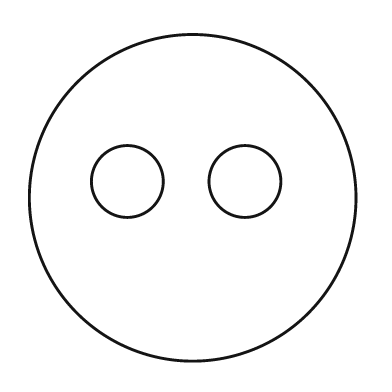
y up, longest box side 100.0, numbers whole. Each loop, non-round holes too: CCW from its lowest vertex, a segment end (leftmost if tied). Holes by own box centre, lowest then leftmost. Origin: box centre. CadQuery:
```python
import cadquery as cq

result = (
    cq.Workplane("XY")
    .moveTo(0.0, 0.0)
    .circle(50.0)
    .moveTo(-20.0, 5.0)
    .circle(11.0)
    .moveTo(16.0, 5.0)
    .circle(11.0)
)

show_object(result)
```